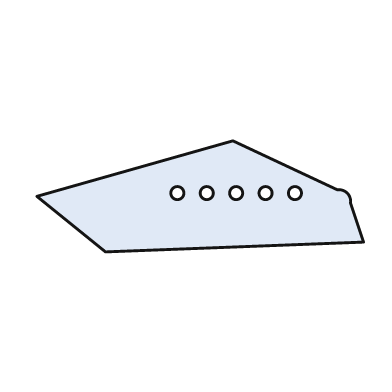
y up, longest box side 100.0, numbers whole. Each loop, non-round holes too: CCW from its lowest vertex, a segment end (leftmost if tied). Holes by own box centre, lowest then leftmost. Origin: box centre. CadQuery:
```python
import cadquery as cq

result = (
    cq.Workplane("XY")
    .moveTo(-29.0, -17.0)
    .lineTo(50.0, -14.0)
    .lineTo(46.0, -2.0)
    .threePointArc((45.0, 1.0), (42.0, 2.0))
    .lineTo(10.0, 17.0)
    .lineTo(-50.0, 0.0)
    .close()
    .moveTo(-7.0, 1.0)
    .circle(2.0)
    .moveTo(2.0, 1.0)
    .circle(2.0)
    .moveTo(11.0, 1.0)
    .circle(2.0)
    .moveTo(20.0, 1.0)
    .circle(2.0)
    .moveTo(29.0, 1.0)
    .circle(2.0)
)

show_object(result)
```